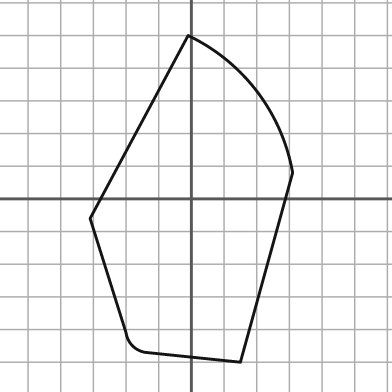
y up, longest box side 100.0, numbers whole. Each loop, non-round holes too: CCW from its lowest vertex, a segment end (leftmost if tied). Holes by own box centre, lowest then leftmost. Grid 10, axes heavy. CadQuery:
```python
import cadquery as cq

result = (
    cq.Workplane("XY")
    .moveTo(15.0, -50.0)
    .lineTo(31.0, 8.0)
    .threePointArc((20.0, 33.0), (-1.0, 50.0))
    .lineTo(-31.0, -6.0)
    .lineTo(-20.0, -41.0)
    .threePointArc((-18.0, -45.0), (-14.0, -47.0))
    .close()
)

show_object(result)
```